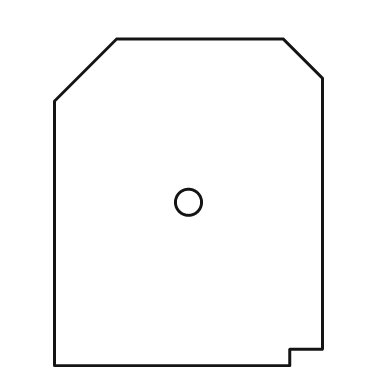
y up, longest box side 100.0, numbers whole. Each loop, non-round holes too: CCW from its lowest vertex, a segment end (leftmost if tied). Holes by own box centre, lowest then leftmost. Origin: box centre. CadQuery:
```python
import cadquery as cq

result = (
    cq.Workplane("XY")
    .moveTo(-41.0, -50.0)
    .lineTo(31.0, -50.0)
    .lineTo(31.0, -45.0)
    .lineTo(41.0, -45.0)
    .lineTo(41.0, 38.0)
    .lineTo(29.0, 50.0)
    .lineTo(-22.0, 50.0)
    .lineTo(-41.0, 31.0)
    .close()
    .moveTo(0.0, 0.0)
    .circle(4.0)
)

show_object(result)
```